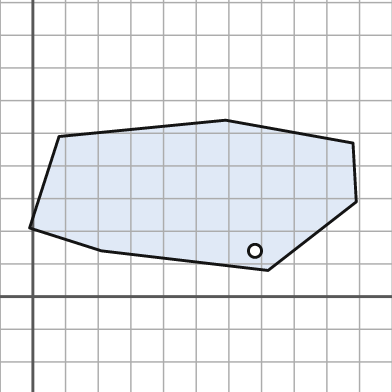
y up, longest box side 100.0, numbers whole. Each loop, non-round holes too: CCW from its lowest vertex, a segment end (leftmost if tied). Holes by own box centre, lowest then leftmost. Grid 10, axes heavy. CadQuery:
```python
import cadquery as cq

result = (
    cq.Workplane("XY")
    .moveTo(72.0, 8.0)
    .lineTo(99.0, 29.0)
    .lineTo(98.0, 47.0)
    .lineTo(59.0, 54.0)
    .lineTo(8.0, 49.0)
    .lineTo(-1.0, 21.0)
    .lineTo(21.0, 14.0)
    .close()
    .moveTo(68.0, 14.0)
    .circle(2.0)
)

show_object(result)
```